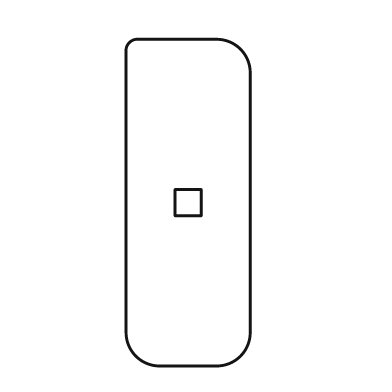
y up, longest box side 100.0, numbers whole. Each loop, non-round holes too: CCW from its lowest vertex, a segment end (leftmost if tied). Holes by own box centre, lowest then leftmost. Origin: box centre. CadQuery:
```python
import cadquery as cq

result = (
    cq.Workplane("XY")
    .moveTo(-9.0, -50.0)
    .lineTo(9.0, -50.0)
    .threePointArc((16.0, -47.0), (19.0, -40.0))
    .lineTo(19.0, 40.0)
    .threePointArc((16.0, 47.0), (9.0, 50.0))
    .lineTo(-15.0, 50.0)
    .threePointArc((-18.0, 49.0), (-19.0, 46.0))
    .lineTo(-19.0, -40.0)
    .threePointArc((-16.0, -47.0), (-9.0, -50.0))
    .close()
    .moveTo(-4.0, -4.0)
    .lineTo(4.0, -4.0)
    .lineTo(4.0, 4.0)
    .lineTo(-4.0, 4.0)
    .close()
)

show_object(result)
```